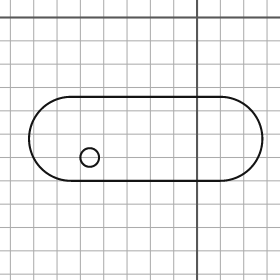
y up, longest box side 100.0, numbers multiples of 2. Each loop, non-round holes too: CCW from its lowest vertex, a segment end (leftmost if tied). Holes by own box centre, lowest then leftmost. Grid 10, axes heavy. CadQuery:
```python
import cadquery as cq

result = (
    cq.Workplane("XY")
    .moveTo(-54.0, -70.0)
    .lineTo(10.0, -70.0)
    .threePointArc((28.0, -52.0), (10.0, -34.0))
    .lineTo(-54.0, -34.0)
    .threePointArc((-72.0, -52.0), (-54.0, -70.0))
    .close()
    .moveTo(-46.0, -60.0)
    .circle(4.0)
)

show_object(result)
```